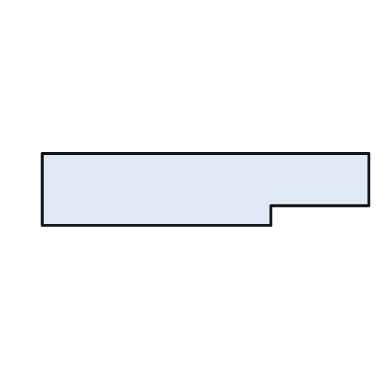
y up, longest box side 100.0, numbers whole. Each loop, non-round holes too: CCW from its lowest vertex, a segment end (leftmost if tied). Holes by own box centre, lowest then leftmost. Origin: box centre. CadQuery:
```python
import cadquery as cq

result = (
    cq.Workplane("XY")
    .moveTo(-50.0, -11.0)
    .lineTo(20.0, -11.0)
    .lineTo(20.0, -5.0)
    .lineTo(50.0, -5.0)
    .lineTo(50.0, 11.0)
    .lineTo(-50.0, 11.0)
    .close()
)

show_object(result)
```